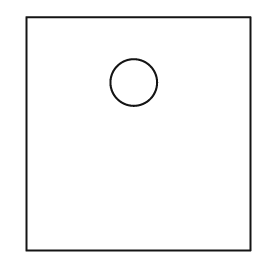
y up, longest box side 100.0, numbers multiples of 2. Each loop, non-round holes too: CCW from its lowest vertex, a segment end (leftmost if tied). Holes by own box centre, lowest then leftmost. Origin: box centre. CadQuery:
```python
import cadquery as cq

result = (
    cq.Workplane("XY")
    .moveTo(-48.0, -50.0)
    .lineTo(48.0, -50.0)
    .lineTo(48.0, 50.0)
    .lineTo(-48.0, 50.0)
    .close()
    .moveTo(-2.0, 22.0)
    .circle(10.0)
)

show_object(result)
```